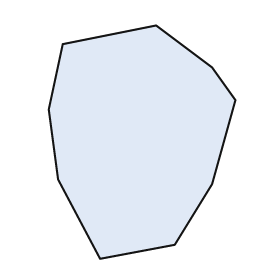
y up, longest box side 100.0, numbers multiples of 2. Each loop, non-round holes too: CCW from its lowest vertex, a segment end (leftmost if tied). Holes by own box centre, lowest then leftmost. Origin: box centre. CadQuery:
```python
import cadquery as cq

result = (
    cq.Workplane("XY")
    .moveTo(-18.0, -50.0)
    .lineTo(14.0, -44.0)
    .lineTo(30.0, -18.0)
    .lineTo(40.0, 18.0)
    .lineTo(30.0, 32.0)
    .lineTo(6.0, 50.0)
    .lineTo(-34.0, 42.0)
    .lineTo(-40.0, 14.0)
    .lineTo(-36.0, -16.0)
    .close()
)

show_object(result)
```